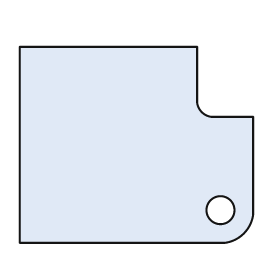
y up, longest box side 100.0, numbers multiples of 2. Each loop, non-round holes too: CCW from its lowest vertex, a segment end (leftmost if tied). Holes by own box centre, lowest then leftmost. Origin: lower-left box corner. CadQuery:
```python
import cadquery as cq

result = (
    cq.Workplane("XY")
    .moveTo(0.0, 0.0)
    .lineTo(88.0, 0.0)
    .threePointArc((96.0, 4.0), (100.0, 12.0))
    .lineTo(100.0, 54.0)
    .lineTo(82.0, 54.0)
    .threePointArc((78.0, 56.0), (76.0, 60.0))
    .lineTo(76.0, 84.0)
    .lineTo(0.0, 84.0)
    .close()
    .moveTo(86.0, 14.0)
    .circle(6.0)
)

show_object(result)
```